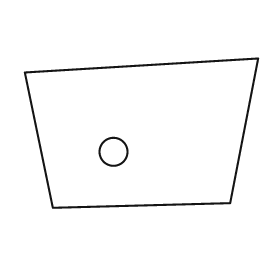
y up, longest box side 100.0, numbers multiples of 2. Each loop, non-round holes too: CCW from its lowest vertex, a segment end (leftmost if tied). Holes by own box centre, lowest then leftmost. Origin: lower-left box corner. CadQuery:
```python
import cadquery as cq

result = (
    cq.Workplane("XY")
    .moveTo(12.0, 0.0)
    .lineTo(88.0, 2.0)
    .lineTo(100.0, 64.0)
    .lineTo(0.0, 58.0)
    .close()
    .moveTo(38.0, 24.0)
    .circle(6.0)
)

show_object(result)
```